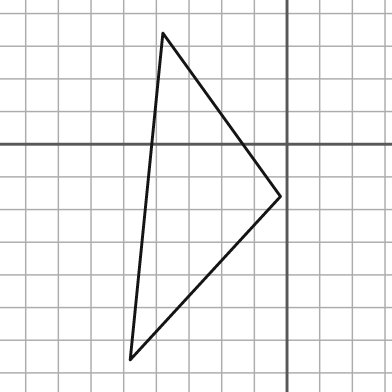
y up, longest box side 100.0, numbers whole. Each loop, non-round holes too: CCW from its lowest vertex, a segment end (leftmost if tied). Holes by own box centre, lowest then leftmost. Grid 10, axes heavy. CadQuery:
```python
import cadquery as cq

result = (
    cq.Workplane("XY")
    .moveTo(-48.0, -66.0)
    .lineTo(-2.0, -16.0)
    .lineTo(-38.0, 34.0)
    .close()
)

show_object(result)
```